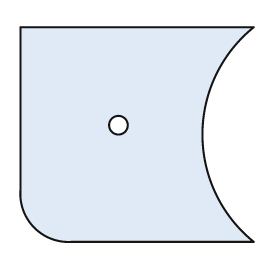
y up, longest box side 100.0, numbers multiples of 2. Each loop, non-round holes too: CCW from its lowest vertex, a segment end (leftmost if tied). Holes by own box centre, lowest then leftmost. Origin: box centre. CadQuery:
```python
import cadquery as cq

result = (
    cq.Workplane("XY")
    .moveTo(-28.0, -46.0)
    .lineTo(50.0, -46.0)
    .threePointArc((28.0, 0.0), (50.0, 46.0))
    .lineTo(-50.0, 46.0)
    .lineTo(-50.0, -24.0)
    .threePointArc((-44.0, -40.0), (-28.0, -46.0))
    .close()
    .moveTo(-8.0, 4.0)
    .circle(4.0)
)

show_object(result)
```